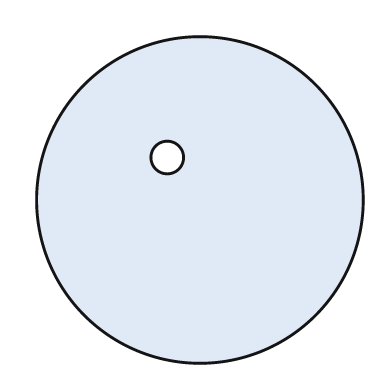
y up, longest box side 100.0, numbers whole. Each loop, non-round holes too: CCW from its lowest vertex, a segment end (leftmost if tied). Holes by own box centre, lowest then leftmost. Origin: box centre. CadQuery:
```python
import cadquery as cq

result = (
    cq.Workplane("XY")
    .moveTo(0.0, 0.0)
    .circle(50.0)
    .moveTo(-10.0, 13.0)
    .circle(5.0)
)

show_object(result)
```